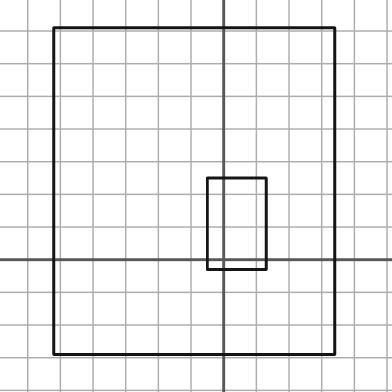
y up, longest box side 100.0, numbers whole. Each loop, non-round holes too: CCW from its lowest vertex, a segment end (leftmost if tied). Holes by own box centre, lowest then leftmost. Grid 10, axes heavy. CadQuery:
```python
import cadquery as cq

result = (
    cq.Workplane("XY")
    .moveTo(-52.0, -29.0)
    .lineTo(34.0, -29.0)
    .lineTo(34.0, 71.0)
    .lineTo(-52.0, 71.0)
    .close()
    .moveTo(-5.0, -3.0)
    .lineTo(13.0, -3.0)
    .lineTo(13.0, 25.0)
    .lineTo(-5.0, 25.0)
    .close()
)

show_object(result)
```